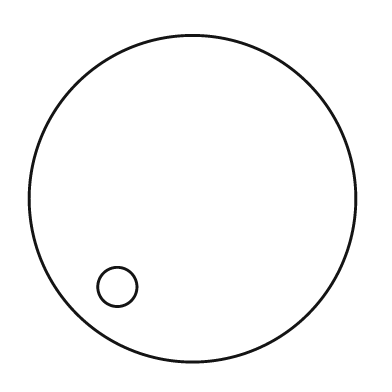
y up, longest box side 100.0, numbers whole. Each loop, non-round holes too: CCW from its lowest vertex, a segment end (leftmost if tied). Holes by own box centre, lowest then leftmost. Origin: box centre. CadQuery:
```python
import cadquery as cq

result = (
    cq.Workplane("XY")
    .moveTo(0.0, 0.0)
    .circle(50.0)
    .moveTo(-23.0, -27.0)
    .circle(6.0)
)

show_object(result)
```